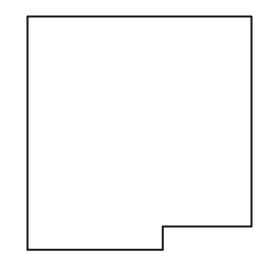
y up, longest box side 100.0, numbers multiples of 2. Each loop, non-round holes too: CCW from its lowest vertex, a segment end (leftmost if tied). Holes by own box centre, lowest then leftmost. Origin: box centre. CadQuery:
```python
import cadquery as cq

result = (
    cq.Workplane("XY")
    .moveTo(-48.0, -50.0)
    .lineTo(10.0, -50.0)
    .lineTo(10.0, -40.0)
    .lineTo(48.0, -40.0)
    .lineTo(48.0, 50.0)
    .lineTo(-48.0, 50.0)
    .close()
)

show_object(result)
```